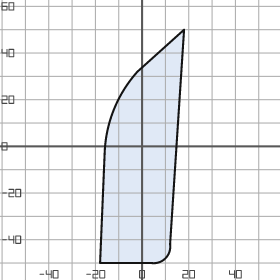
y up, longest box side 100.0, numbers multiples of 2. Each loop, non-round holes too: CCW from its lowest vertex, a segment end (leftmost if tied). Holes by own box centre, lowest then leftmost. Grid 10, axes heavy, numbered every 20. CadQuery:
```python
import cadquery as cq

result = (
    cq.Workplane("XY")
    .moveTo(-18.0, -50.0)
    .lineTo(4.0, -50.0)
    .threePointArc((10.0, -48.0), (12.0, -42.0))
    .lineTo(18.0, 50.0)
    .lineTo(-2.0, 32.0)
    .threePointArc((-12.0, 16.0), (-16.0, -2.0))
    .close()
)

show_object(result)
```